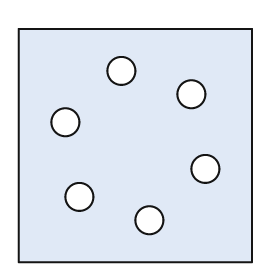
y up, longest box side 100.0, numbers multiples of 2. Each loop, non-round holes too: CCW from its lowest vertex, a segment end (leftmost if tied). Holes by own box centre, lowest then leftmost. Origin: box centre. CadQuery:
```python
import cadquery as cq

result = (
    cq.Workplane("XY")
    .moveTo(-50.0, -50.0)
    .lineTo(50.0, -50.0)
    .lineTo(50.0, 50.0)
    .lineTo(-50.0, 50.0)
    .close()
    .moveTo(6.0, -32.0)
    .circle(6.0)
    .moveTo(-24.0, -22.0)
    .circle(6.0)
    .moveTo(30.0, -10.0)
    .circle(6.0)
    .moveTo(-30.0, 10.0)
    .circle(6.0)
    .moveTo(24.0, 22.0)
    .circle(6.0)
    .moveTo(-6.0, 32.0)
    .circle(6.0)
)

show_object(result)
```